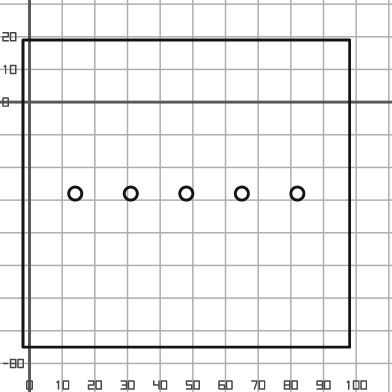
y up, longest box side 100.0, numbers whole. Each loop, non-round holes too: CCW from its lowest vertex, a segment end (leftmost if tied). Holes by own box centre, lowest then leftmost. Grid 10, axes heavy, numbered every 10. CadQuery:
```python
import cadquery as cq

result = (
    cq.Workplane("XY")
    .moveTo(-2.0, -75.0)
    .lineTo(98.0, -75.0)
    .lineTo(98.0, 19.0)
    .lineTo(-2.0, 19.0)
    .close()
    .moveTo(14.0, -28.0)
    .circle(2.0)
    .moveTo(31.0, -28.0)
    .circle(2.0)
    .moveTo(48.0, -28.0)
    .circle(2.0)
    .moveTo(65.0, -28.0)
    .circle(2.0)
    .moveTo(82.0, -28.0)
    .circle(2.0)
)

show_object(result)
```